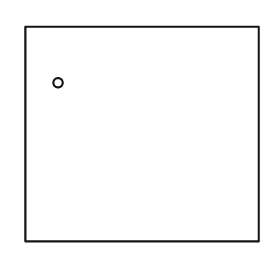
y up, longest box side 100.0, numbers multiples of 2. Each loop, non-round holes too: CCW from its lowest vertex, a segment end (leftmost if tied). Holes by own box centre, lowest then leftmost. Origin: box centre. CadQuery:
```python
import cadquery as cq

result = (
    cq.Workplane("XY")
    .moveTo(-50.0, -46.0)
    .lineTo(50.0, -46.0)
    .lineTo(50.0, 46.0)
    .lineTo(-50.0, 46.0)
    .close()
    .moveTo(-36.0, 22.0)
    .circle(2.0)
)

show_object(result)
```